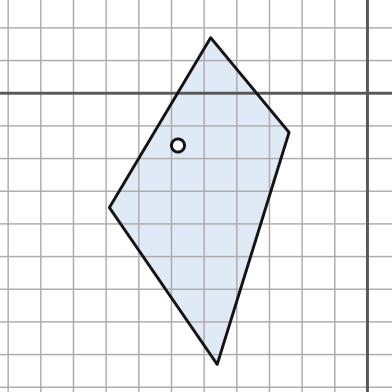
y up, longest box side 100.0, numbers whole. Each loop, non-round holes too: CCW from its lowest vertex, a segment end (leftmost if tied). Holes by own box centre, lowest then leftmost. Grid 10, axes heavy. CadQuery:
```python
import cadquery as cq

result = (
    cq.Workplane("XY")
    .moveTo(-46.0, -83.0)
    .lineTo(-24.0, -12.0)
    .lineTo(-48.0, 17.0)
    .lineTo(-79.0, -35.0)
    .close()
    .moveTo(-58.0, -16.0)
    .circle(2.0)
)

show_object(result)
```